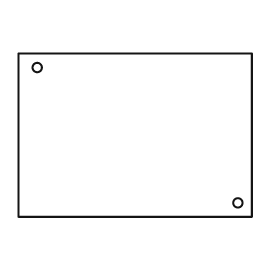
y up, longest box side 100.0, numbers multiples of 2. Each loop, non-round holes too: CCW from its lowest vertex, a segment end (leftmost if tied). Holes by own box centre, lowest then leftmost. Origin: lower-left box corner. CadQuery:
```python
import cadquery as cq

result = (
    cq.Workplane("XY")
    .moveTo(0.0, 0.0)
    .lineTo(100.0, 0.0)
    .lineTo(100.0, 70.0)
    .lineTo(0.0, 70.0)
    .close()
    .moveTo(94.0, 6.0)
    .circle(2.0)
    .moveTo(8.0, 64.0)
    .circle(2.0)
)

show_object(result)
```